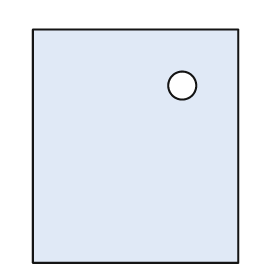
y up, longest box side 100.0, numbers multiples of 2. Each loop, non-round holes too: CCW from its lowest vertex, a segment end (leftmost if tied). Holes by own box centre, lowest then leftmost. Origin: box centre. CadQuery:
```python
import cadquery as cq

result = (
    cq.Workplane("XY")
    .moveTo(-44.0, -50.0)
    .lineTo(44.0, -50.0)
    .lineTo(44.0, 50.0)
    .lineTo(-44.0, 50.0)
    .close()
    .moveTo(20.0, 26.0)
    .circle(6.0)
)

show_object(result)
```